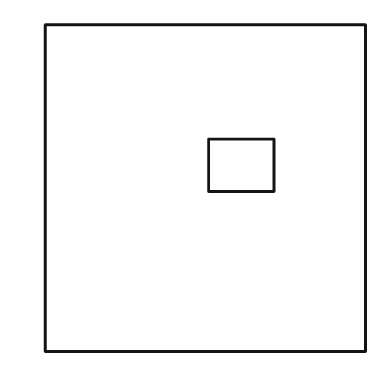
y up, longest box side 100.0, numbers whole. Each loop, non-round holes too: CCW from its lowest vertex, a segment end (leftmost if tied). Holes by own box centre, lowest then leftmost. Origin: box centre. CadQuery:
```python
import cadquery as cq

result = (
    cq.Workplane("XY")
    .moveTo(-49.0, -50.0)
    .lineTo(49.0, -50.0)
    .lineTo(49.0, 50.0)
    .lineTo(-49.0, 50.0)
    .close()
    .moveTo(1.0, -1.0)
    .lineTo(21.0, -1.0)
    .lineTo(21.0, 15.0)
    .lineTo(1.0, 15.0)
    .close()
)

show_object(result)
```